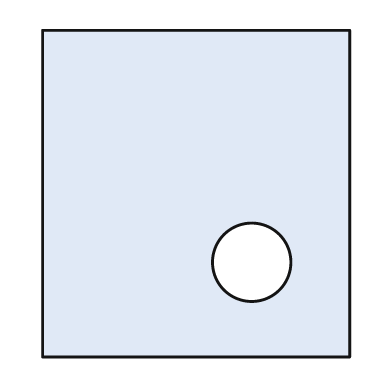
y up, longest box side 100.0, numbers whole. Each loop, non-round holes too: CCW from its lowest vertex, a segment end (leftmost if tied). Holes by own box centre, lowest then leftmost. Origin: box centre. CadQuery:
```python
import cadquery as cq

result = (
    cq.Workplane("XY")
    .moveTo(-47.0, -50.0)
    .lineTo(47.0, -50.0)
    .lineTo(47.0, 50.0)
    .lineTo(-47.0, 50.0)
    .close()
    .moveTo(17.0, -21.0)
    .circle(12.0)
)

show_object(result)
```